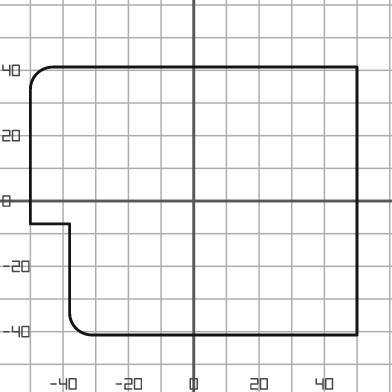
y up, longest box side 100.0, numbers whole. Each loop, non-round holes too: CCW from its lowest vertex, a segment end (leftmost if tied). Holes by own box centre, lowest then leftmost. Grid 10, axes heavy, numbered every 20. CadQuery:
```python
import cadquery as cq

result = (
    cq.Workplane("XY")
    .moveTo(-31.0, -41.0)
    .lineTo(50.0, -41.0)
    .lineTo(50.0, 41.0)
    .lineTo(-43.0, 41.0)
    .threePointArc((-48.0, 39.0), (-50.0, 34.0))
    .lineTo(-50.0, -7.0)
    .lineTo(-38.0, -7.0)
    .lineTo(-38.0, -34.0)
    .threePointArc((-36.0, -39.0), (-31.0, -41.0))
    .close()
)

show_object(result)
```